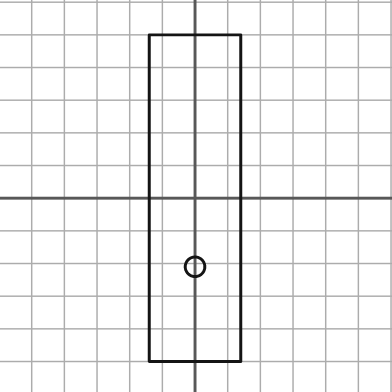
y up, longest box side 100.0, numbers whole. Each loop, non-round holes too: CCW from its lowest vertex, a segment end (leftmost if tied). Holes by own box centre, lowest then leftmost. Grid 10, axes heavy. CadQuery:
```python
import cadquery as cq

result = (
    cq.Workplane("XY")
    .moveTo(-14.0, -50.0)
    .lineTo(14.0, -50.0)
    .lineTo(14.0, 50.0)
    .lineTo(-14.0, 50.0)
    .close()
    .moveTo(0.0, -21.0)
    .circle(3.0)
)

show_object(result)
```